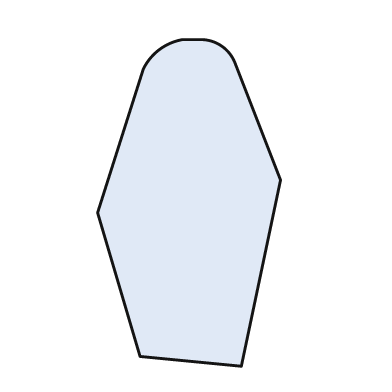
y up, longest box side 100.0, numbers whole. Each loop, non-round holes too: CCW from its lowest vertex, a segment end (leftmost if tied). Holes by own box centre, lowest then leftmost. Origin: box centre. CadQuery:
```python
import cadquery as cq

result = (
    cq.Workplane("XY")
    .moveTo(16.0, -50.0)
    .lineTo(28.0, 7.0)
    .lineTo(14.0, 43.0)
    .threePointArc((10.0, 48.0), (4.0, 50.0))
    .lineTo(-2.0, 50.0)
    .threePointArc((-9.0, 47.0), (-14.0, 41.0))
    .lineTo(-28.0, -3.0)
    .lineTo(-15.0, -47.0)
    .close()
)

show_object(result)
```